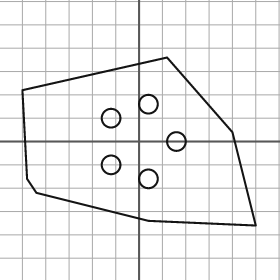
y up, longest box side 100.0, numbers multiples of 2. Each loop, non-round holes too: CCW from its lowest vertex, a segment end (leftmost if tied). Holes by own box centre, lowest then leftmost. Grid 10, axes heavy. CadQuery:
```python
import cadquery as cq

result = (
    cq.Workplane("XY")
    .moveTo(50.0, -36.0)
    .lineTo(40.0, 4.0)
    .lineTo(12.0, 36.0)
    .lineTo(-50.0, 22.0)
    .lineTo(-48.0, -16.0)
    .lineTo(-44.0, -22.0)
    .lineTo(4.0, -34.0)
    .close()
    .moveTo(4.0, -16.0)
    .circle(4.0)
    .moveTo(-12.0, -10.0)
    .circle(4.0)
    .moveTo(16.0, 0.0)
    .circle(4.0)
    .moveTo(-12.0, 10.0)
    .circle(4.0)
    .moveTo(4.0, 16.0)
    .circle(4.0)
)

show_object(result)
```